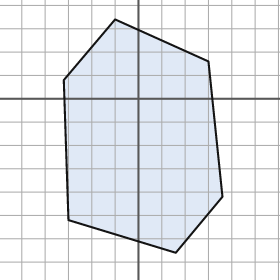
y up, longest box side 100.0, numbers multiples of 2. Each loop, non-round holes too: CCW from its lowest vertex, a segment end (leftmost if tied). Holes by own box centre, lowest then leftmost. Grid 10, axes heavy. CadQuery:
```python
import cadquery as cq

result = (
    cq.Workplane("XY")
    .moveTo(16.0, -66.0)
    .lineTo(36.0, -42.0)
    .lineTo(30.0, 16.0)
    .lineTo(-10.0, 34.0)
    .lineTo(-32.0, 8.0)
    .lineTo(-30.0, -52.0)
    .close()
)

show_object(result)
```